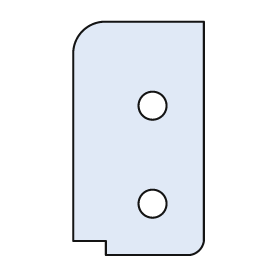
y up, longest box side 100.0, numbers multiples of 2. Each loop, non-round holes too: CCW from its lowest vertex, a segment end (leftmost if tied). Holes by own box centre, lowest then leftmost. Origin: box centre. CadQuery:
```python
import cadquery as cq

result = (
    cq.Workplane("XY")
    .moveTo(-14.0, -50.0)
    .lineTo(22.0, -50.0)
    .threePointArc((26.0, -48.0), (28.0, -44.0))
    .lineTo(28.0, 50.0)
    .lineTo(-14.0, 50.0)
    .threePointArc((-24.0, 46.0), (-28.0, 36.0))
    .lineTo(-28.0, -44.0)
    .lineTo(-14.0, -44.0)
    .close()
    .moveTo(6.0, -28.0)
    .circle(6.0)
    .moveTo(6.0, 14.0)
    .circle(6.0)
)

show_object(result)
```